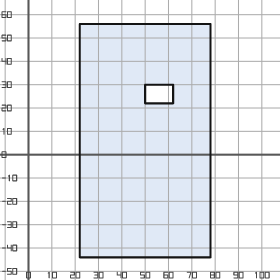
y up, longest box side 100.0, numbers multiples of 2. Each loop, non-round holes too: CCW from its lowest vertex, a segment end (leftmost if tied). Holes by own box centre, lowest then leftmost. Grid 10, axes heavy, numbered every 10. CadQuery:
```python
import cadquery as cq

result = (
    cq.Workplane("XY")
    .moveTo(22.0, -44.0)
    .lineTo(78.0, -44.0)
    .lineTo(78.0, 56.0)
    .lineTo(22.0, 56.0)
    .close()
    .moveTo(50.0, 22.0)
    .lineTo(62.0, 22.0)
    .lineTo(62.0, 30.0)
    .lineTo(50.0, 30.0)
    .close()
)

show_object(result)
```